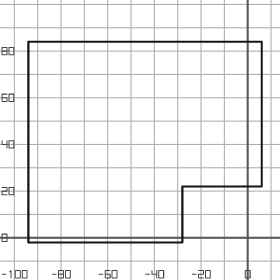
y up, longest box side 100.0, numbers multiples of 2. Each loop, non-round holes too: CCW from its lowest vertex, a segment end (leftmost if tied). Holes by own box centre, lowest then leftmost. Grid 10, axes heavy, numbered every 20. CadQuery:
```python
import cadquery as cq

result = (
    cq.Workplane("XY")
    .moveTo(-94.0, -2.0)
    .lineTo(-28.0, -2.0)
    .lineTo(-28.0, 22.0)
    .lineTo(6.0, 22.0)
    .lineTo(6.0, 84.0)
    .lineTo(-94.0, 84.0)
    .close()
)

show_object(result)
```